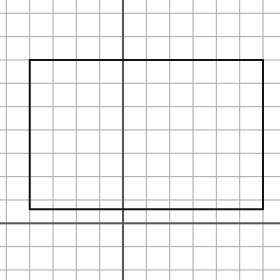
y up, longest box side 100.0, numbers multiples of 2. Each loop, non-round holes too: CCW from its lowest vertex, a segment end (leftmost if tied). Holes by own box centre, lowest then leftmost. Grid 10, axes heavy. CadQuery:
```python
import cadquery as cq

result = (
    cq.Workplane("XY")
    .moveTo(-40.0, 6.0)
    .lineTo(60.0, 6.0)
    .lineTo(60.0, 70.0)
    .lineTo(-40.0, 70.0)
    .close()
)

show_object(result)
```